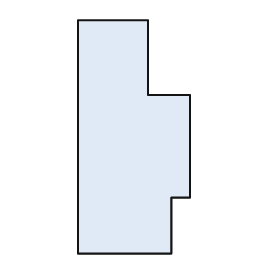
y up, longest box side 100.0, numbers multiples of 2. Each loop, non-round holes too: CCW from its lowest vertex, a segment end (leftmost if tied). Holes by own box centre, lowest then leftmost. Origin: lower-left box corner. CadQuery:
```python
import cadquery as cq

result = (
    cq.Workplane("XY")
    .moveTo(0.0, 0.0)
    .lineTo(40.0, 0.0)
    .lineTo(40.0, 24.0)
    .lineTo(48.0, 24.0)
    .lineTo(48.0, 68.0)
    .lineTo(30.0, 68.0)
    .lineTo(30.0, 100.0)
    .lineTo(0.0, 100.0)
    .close()
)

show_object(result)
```